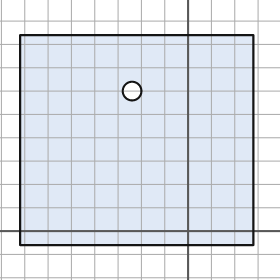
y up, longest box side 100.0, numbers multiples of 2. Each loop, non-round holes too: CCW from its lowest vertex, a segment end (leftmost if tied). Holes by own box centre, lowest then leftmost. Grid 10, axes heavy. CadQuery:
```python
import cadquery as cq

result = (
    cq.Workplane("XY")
    .moveTo(-72.0, -6.0)
    .lineTo(28.0, -6.0)
    .lineTo(28.0, 84.0)
    .lineTo(-72.0, 84.0)
    .close()
    .moveTo(-24.0, 60.0)
    .circle(4.0)
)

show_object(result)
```